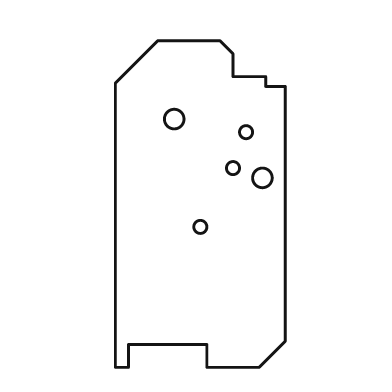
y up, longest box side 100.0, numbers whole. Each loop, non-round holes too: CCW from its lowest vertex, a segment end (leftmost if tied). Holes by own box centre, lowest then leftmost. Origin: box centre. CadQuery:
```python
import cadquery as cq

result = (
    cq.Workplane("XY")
    .moveTo(-26.0, -50.0)
    .lineTo(-22.0, -50.0)
    .lineTo(-22.0, -43.0)
    .lineTo(2.0, -43.0)
    .lineTo(2.0, -50.0)
    .lineTo(18.0, -50.0)
    .lineTo(26.0, -42.0)
    .lineTo(26.0, 36.0)
    .lineTo(20.0, 36.0)
    .lineTo(20.0, 39.0)
    .lineTo(10.0, 39.0)
    .lineTo(10.0, 46.0)
    .lineTo(6.0, 50.0)
    .lineTo(-13.0, 50.0)
    .lineTo(-26.0, 37.0)
    .close()
    .moveTo(0.0, -7.0)
    .circle(2.0)
    .moveTo(19.0, 8.0)
    .circle(3.0)
    .moveTo(10.0, 11.0)
    .circle(2.0)
    .moveTo(14.0, 22.0)
    .circle(2.0)
    .moveTo(-8.0, 26.0)
    .circle(3.0)
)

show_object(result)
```